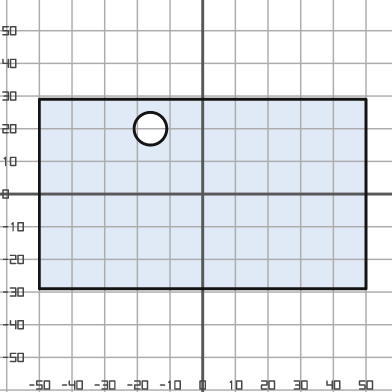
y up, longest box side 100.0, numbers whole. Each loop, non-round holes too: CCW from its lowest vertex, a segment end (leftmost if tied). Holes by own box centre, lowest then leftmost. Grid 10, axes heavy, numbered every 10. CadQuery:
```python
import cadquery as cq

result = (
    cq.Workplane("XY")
    .moveTo(-50.0, -29.0)
    .lineTo(50.0, -29.0)
    .lineTo(50.0, 29.0)
    .lineTo(-50.0, 29.0)
    .close()
    .moveTo(-16.0, 20.0)
    .circle(5.0)
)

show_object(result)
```